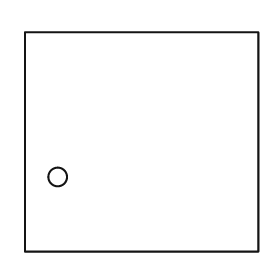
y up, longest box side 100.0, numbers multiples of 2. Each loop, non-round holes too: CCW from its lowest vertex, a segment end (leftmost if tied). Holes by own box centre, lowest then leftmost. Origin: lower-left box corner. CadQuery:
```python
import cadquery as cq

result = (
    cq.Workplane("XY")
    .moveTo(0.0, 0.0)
    .lineTo(100.0, 0.0)
    .lineTo(100.0, 94.0)
    .lineTo(0.0, 94.0)
    .close()
    .moveTo(14.0, 32.0)
    .circle(4.0)
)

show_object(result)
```